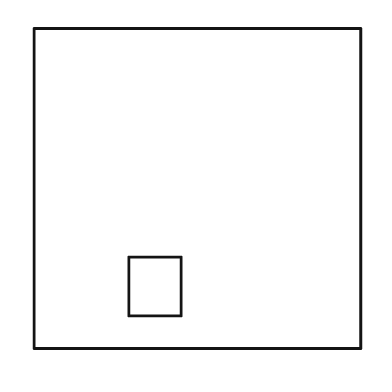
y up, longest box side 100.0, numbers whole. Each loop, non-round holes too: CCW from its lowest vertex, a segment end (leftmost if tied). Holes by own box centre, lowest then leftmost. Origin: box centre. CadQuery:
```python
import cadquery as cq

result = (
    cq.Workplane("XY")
    .moveTo(-50.0, -49.0)
    .lineTo(50.0, -49.0)
    .lineTo(50.0, 49.0)
    .lineTo(-50.0, 49.0)
    .close()
    .moveTo(-21.0, -39.0)
    .lineTo(-5.0, -39.0)
    .lineTo(-5.0, -21.0)
    .lineTo(-21.0, -21.0)
    .close()
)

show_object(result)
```